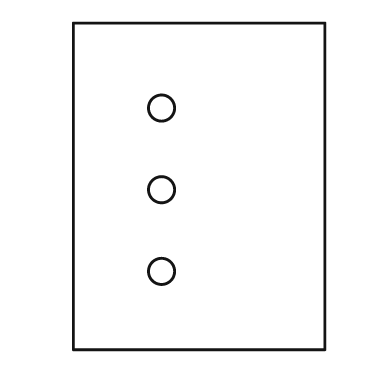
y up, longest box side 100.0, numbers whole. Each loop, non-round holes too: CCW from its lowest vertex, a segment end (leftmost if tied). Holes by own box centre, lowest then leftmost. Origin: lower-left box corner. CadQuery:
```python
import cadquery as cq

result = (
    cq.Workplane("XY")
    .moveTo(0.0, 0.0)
    .lineTo(77.0, 0.0)
    .lineTo(77.0, 100.0)
    .lineTo(0.0, 100.0)
    .close()
    .moveTo(27.0, 24.0)
    .circle(4.0)
    .moveTo(27.0, 49.0)
    .circle(4.0)
    .moveTo(27.0, 74.0)
    .circle(4.0)
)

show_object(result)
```